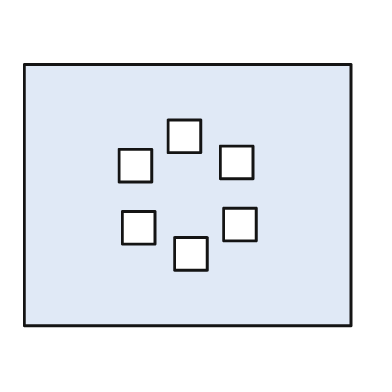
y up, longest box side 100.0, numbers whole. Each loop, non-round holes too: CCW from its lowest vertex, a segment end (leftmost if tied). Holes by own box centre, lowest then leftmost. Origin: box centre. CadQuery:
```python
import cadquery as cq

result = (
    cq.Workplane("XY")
    .moveTo(-50.0, -40.0)
    .lineTo(50.0, -40.0)
    .lineTo(50.0, 40.0)
    .lineTo(-50.0, 40.0)
    .close()
    .moveTo(-4.0, -23.0)
    .lineTo(6.0, -23.0)
    .lineTo(6.0, -13.0)
    .lineTo(-4.0, -13.0)
    .close()
    .moveTo(-20.0, -15.0)
    .lineTo(-10.0, -15.0)
    .lineTo(-10.0, -5.0)
    .lineTo(-20.0, -5.0)
    .close()
    .moveTo(11.0, -14.0)
    .lineTo(21.0, -14.0)
    .lineTo(21.0, -4.0)
    .lineTo(11.0, -4.0)
    .close()
    .moveTo(-21.0, 4.0)
    .lineTo(-11.0, 4.0)
    .lineTo(-11.0, 14.0)
    .lineTo(-21.0, 14.0)
    .close()
    .moveTo(10.0, 5.0)
    .lineTo(20.0, 5.0)
    .lineTo(20.0, 15.0)
    .lineTo(10.0, 15.0)
    .close()
    .moveTo(-6.0, 13.0)
    .lineTo(4.0, 13.0)
    .lineTo(4.0, 23.0)
    .lineTo(-6.0, 23.0)
    .close()
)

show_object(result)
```